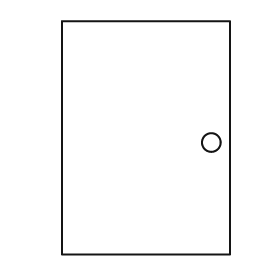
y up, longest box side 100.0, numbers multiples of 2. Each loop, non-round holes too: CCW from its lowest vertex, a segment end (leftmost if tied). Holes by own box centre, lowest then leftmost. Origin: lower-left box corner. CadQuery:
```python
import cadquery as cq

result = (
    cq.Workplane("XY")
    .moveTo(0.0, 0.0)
    .lineTo(72.0, 0.0)
    .lineTo(72.0, 100.0)
    .lineTo(0.0, 100.0)
    .close()
    .moveTo(64.0, 48.0)
    .circle(4.0)
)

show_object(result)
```